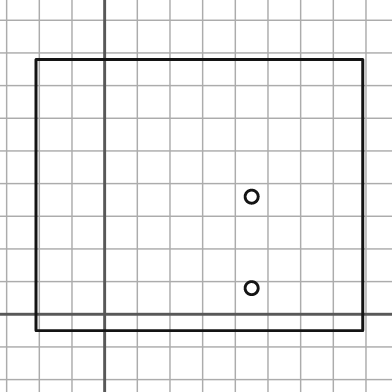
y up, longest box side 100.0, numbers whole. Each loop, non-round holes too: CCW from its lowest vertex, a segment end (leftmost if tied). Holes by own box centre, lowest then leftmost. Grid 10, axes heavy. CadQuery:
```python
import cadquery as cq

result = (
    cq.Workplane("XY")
    .moveTo(-21.0, -5.0)
    .lineTo(79.0, -5.0)
    .lineTo(79.0, 78.0)
    .lineTo(-21.0, 78.0)
    .close()
    .moveTo(45.0, 8.0)
    .circle(2.0)
    .moveTo(45.0, 36.0)
    .circle(2.0)
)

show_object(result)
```